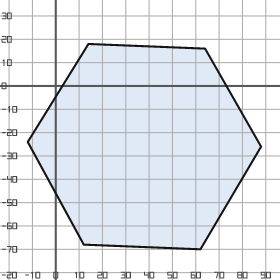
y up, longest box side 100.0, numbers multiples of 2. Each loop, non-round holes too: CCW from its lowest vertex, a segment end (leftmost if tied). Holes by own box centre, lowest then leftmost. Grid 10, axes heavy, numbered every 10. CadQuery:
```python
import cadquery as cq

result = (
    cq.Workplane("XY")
    .moveTo(62.0, -70.0)
    .lineTo(88.0, -26.0)
    .lineTo(64.0, 16.0)
    .lineTo(14.0, 18.0)
    .lineTo(-12.0, -24.0)
    .lineTo(12.0, -68.0)
    .close()
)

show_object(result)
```